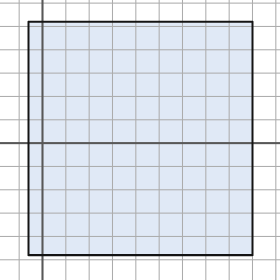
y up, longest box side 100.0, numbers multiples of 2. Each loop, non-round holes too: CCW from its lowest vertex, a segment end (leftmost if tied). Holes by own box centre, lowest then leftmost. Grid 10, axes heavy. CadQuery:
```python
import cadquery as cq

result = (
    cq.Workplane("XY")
    .moveTo(-6.0, -48.0)
    .lineTo(90.0, -48.0)
    .lineTo(90.0, 52.0)
    .lineTo(-6.0, 52.0)
    .close()
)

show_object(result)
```